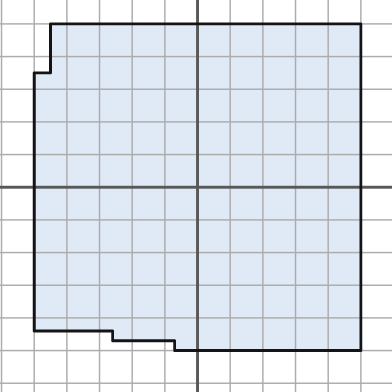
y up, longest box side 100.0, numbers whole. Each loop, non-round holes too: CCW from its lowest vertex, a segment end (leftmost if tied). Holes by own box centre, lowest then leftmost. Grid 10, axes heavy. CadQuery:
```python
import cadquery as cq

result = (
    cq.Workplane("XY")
    .moveTo(-7.0, -50.0)
    .lineTo(50.0, -50.0)
    .lineTo(50.0, 50.0)
    .lineTo(-45.0, 50.0)
    .lineTo(-45.0, 35.0)
    .lineTo(-50.0, 35.0)
    .lineTo(-50.0, -44.0)
    .lineTo(-26.0, -44.0)
    .lineTo(-26.0, -47.0)
    .lineTo(-7.0, -47.0)
    .close()
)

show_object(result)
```